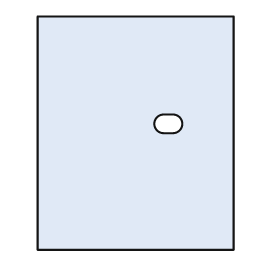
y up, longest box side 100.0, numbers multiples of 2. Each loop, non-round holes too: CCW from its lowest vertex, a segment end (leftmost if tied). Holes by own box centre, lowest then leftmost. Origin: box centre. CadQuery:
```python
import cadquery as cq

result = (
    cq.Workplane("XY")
    .moveTo(-42.0, -50.0)
    .lineTo(42.0, -50.0)
    .lineTo(42.0, 50.0)
    .lineTo(-42.0, 50.0)
    .close()
    .moveTo(12.0, 0.0)
    .lineTo(16.0, 0.0)
    .threePointArc((20.0, 4.0), (16.0, 8.0))
    .lineTo(12.0, 8.0)
    .threePointArc((8.0, 4.0), (12.0, 0.0))
    .close()
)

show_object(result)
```